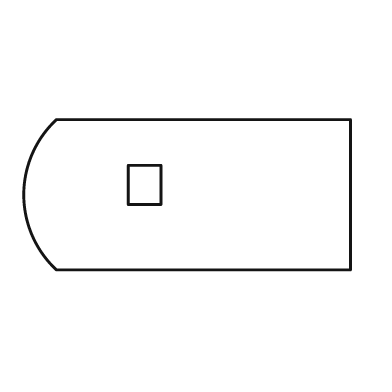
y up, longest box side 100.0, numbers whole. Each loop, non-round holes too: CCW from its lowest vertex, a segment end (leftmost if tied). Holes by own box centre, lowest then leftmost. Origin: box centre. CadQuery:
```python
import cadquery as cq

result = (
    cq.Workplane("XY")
    .moveTo(-40.0, -23.0)
    .lineTo(50.0, -23.0)
    .lineTo(50.0, 23.0)
    .lineTo(-40.0, 23.0)
    .threePointArc((-50.0, 0.0), (-40.0, -23.0))
    .close()
    .moveTo(-18.0, -3.0)
    .lineTo(-8.0, -3.0)
    .lineTo(-8.0, 9.0)
    .lineTo(-18.0, 9.0)
    .close()
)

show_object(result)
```